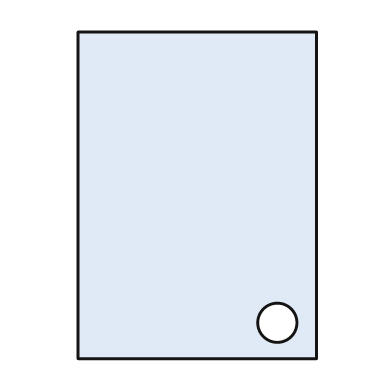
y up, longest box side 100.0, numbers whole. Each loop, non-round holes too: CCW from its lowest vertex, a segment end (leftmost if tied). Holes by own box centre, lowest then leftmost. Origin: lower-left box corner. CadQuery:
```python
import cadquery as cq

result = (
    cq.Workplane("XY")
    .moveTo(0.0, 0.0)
    .lineTo(73.0, 0.0)
    .lineTo(73.0, 100.0)
    .lineTo(0.0, 100.0)
    .close()
    .moveTo(61.0, 11.0)
    .circle(6.0)
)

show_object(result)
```